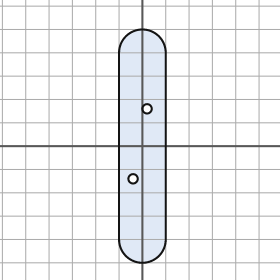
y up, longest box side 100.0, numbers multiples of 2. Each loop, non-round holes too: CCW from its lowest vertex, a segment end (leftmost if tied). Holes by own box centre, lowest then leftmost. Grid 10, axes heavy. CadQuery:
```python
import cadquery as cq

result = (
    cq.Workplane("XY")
    .moveTo(-10.0, -40.0)
    .threePointArc((0.0, -50.0), (10.0, -40.0))
    .lineTo(10.0, 40.0)
    .threePointArc((0.0, 50.0), (-10.0, 40.0))
    .close()
    .moveTo(-4.0, -14.0)
    .circle(2.0)
    .moveTo(2.0, 16.0)
    .circle(2.0)
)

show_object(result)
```